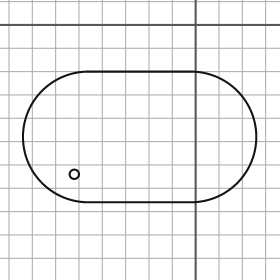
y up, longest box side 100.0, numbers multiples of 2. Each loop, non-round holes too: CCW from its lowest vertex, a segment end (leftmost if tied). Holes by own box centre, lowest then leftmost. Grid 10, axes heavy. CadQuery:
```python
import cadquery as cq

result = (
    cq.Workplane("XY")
    .moveTo(-46.0, -76.0)
    .lineTo(-2.0, -76.0)
    .threePointArc((26.0, -48.0), (-2.0, -20.0))
    .lineTo(-46.0, -20.0)
    .threePointArc((-74.0, -48.0), (-46.0, -76.0))
    .close()
    .moveTo(-52.0, -64.0)
    .circle(2.0)
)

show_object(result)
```